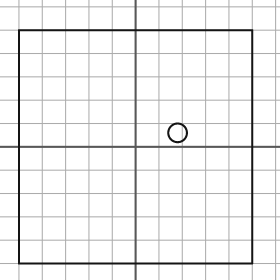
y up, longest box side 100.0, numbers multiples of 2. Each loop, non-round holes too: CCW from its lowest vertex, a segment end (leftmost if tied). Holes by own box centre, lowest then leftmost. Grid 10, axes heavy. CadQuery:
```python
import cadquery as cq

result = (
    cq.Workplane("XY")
    .moveTo(-50.0, -50.0)
    .lineTo(50.0, -50.0)
    .lineTo(50.0, 50.0)
    .lineTo(-50.0, 50.0)
    .close()
    .moveTo(18.0, 6.0)
    .circle(4.0)
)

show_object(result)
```